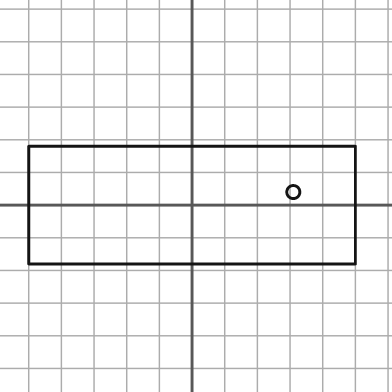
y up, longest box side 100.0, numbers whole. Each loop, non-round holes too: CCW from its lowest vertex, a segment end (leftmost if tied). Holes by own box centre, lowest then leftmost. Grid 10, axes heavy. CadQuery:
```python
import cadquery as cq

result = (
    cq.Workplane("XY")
    .moveTo(-50.0, -18.0)
    .lineTo(50.0, -18.0)
    .lineTo(50.0, 18.0)
    .lineTo(-50.0, 18.0)
    .close()
    .moveTo(31.0, 4.0)
    .circle(2.0)
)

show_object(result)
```